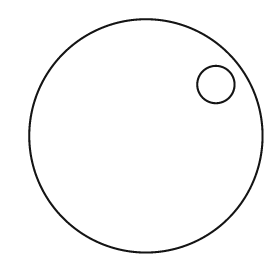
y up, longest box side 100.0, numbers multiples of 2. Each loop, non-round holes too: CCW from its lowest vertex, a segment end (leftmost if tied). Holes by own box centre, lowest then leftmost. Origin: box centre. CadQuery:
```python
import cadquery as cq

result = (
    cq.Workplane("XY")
    .moveTo(0.0, 0.0)
    .circle(50.0)
    .moveTo(30.0, 22.0)
    .circle(8.0)
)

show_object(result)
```